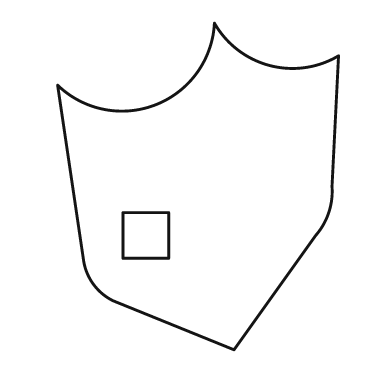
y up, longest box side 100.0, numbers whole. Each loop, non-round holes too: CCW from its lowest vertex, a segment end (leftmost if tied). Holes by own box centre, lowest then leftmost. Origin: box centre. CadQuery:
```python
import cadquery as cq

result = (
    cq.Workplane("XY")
    .moveTo(11.0, -50.0)
    .lineTo(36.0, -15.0)
    .threePointArc((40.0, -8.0), (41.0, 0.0))
    .lineTo(43.0, 40.0)
    .threePointArc((22.0, 37.0), (5.0, 50.0))
    .threePointArc((-13.0, 25.0), (-43.0, 31.0))
    .lineTo(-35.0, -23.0)
    .threePointArc((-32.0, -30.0), (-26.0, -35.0))
    .close()
    .moveTo(-23.0, -22.0)
    .lineTo(-9.0, -22.0)
    .lineTo(-9.0, -8.0)
    .lineTo(-23.0, -8.0)
    .close()
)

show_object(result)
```